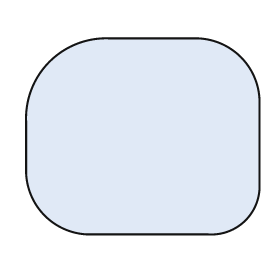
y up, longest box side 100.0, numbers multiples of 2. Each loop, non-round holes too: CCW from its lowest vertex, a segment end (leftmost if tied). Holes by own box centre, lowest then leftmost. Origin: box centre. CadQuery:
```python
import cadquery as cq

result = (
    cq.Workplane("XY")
    .moveTo(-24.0, -42.0)
    .lineTo(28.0, -42.0)
    .threePointArc((44.0, -36.0), (50.0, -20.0))
    .lineTo(50.0, 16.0)
    .threePointArc((42.0, 34.0), (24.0, 42.0))
    .lineTo(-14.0, 42.0)
    .threePointArc((-40.0, 32.0), (-50.0, 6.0))
    .lineTo(-50.0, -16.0)
    .threePointArc((-42.0, -34.0), (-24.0, -42.0))
    .close()
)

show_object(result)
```